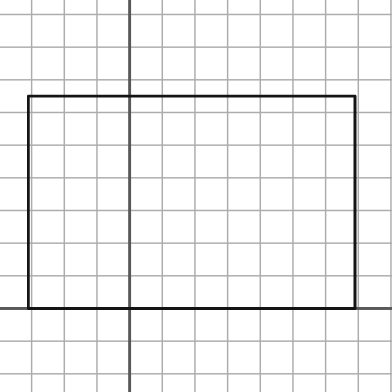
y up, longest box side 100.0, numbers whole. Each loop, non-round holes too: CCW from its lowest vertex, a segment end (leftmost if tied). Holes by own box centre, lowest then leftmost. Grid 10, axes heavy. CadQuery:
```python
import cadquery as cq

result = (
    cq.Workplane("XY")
    .moveTo(-31.0, 0.0)
    .lineTo(69.0, 0.0)
    .lineTo(69.0, 65.0)
    .lineTo(-31.0, 65.0)
    .close()
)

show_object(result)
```